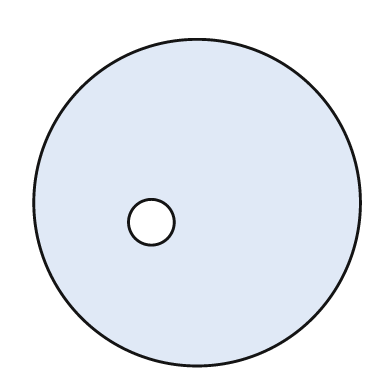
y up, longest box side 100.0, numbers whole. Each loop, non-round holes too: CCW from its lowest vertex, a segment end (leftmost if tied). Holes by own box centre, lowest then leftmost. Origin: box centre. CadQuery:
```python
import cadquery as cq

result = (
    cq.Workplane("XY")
    .moveTo(0.0, 0.0)
    .circle(50.0)
    .moveTo(-14.0, -6.0)
    .circle(7.0)
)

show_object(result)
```